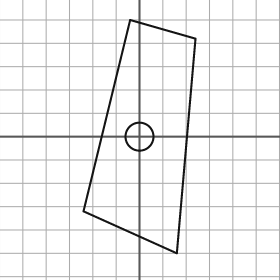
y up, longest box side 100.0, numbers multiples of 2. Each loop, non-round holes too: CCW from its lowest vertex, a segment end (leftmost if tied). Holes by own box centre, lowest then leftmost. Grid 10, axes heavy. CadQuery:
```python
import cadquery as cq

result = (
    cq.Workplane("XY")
    .moveTo(16.0, -50.0)
    .lineTo(24.0, 42.0)
    .lineTo(-4.0, 50.0)
    .lineTo(-24.0, -32.0)
    .close()
    .moveTo(0.0, 0.0)
    .circle(6.0)
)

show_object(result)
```